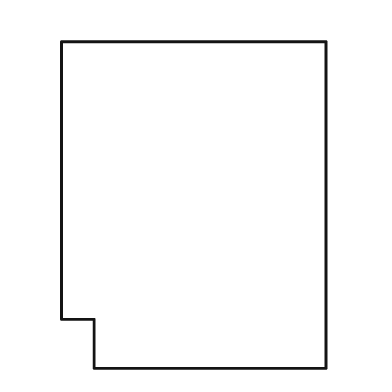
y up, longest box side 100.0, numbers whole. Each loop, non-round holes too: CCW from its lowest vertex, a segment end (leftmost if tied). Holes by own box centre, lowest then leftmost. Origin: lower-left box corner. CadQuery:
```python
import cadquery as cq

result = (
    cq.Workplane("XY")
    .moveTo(10.0, 0.0)
    .lineTo(81.0, 0.0)
    .lineTo(81.0, 100.0)
    .lineTo(0.0, 100.0)
    .lineTo(0.0, 15.0)
    .lineTo(10.0, 15.0)
    .close()
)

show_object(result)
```